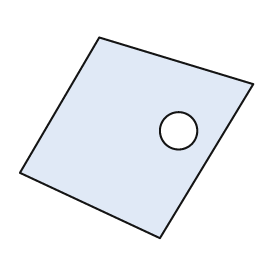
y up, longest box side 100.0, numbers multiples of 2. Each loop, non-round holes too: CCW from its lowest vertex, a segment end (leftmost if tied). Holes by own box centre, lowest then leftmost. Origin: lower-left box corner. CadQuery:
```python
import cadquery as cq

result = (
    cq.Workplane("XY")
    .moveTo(60.0, 0.0)
    .lineTo(100.0, 66.0)
    .lineTo(34.0, 86.0)
    .lineTo(0.0, 28.0)
    .close()
    .moveTo(68.0, 46.0)
    .circle(8.0)
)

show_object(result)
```